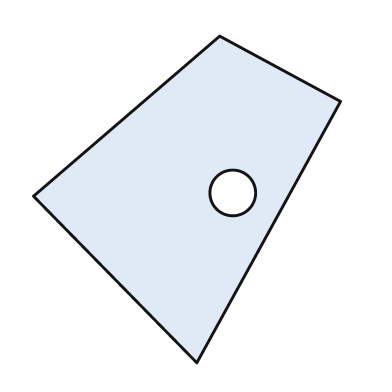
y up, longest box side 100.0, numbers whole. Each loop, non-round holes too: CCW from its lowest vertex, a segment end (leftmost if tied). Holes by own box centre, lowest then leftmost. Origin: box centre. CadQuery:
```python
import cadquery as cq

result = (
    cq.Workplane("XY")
    .moveTo(3.0, -50.0)
    .lineTo(47.0, 30.0)
    .lineTo(10.0, 50.0)
    .lineTo(-47.0, 1.0)
    .close()
    .moveTo(14.0, 2.0)
    .circle(7.0)
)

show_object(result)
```